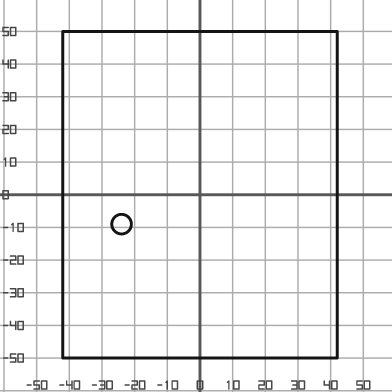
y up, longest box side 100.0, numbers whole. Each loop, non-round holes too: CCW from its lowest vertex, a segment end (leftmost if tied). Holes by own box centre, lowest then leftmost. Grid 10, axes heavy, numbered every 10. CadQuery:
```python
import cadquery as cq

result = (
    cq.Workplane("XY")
    .moveTo(-42.0, -50.0)
    .lineTo(42.0, -50.0)
    .lineTo(42.0, 50.0)
    .lineTo(-42.0, 50.0)
    .close()
    .moveTo(-24.0, -9.0)
    .circle(3.0)
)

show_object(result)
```